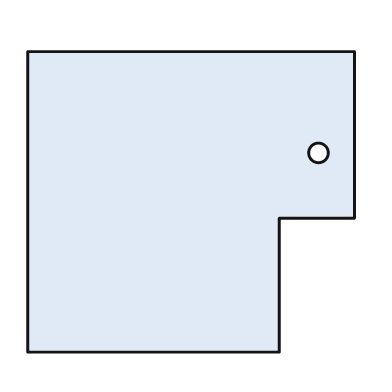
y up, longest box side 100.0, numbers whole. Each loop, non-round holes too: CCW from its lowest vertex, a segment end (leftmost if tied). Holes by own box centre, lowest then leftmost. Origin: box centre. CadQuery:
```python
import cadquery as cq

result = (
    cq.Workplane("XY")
    .moveTo(-50.0, -46.0)
    .lineTo(27.0, -46.0)
    .lineTo(27.0, -5.0)
    .lineTo(50.0, -5.0)
    .lineTo(50.0, 46.0)
    .lineTo(-50.0, 46.0)
    .close()
    .moveTo(39.0, 15.0)
    .circle(3.0)
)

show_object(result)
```